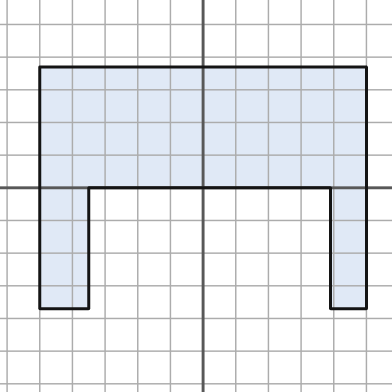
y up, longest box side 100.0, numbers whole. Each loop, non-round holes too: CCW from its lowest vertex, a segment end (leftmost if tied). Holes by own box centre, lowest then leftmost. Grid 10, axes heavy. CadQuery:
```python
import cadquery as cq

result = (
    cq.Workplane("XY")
    .moveTo(-50.0, -37.0)
    .lineTo(-35.0, -37.0)
    .lineTo(-35.0, 0.0)
    .lineTo(39.0, 0.0)
    .lineTo(39.0, -37.0)
    .lineTo(50.0, -37.0)
    .lineTo(50.0, 37.0)
    .lineTo(-50.0, 37.0)
    .close()
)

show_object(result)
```